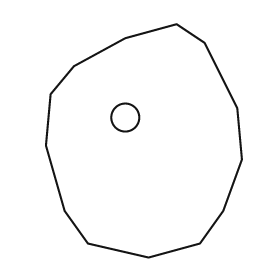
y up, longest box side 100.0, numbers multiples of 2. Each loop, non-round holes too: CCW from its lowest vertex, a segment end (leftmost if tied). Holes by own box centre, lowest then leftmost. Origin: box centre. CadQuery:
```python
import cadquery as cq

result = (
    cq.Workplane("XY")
    .moveTo(2.0, -50.0)
    .lineTo(24.0, -44.0)
    .lineTo(34.0, -30.0)
    .lineTo(42.0, -8.0)
    .lineTo(40.0, 14.0)
    .lineTo(26.0, 42.0)
    .lineTo(14.0, 50.0)
    .lineTo(-8.0, 44.0)
    .lineTo(-30.0, 32.0)
    .lineTo(-40.0, 20.0)
    .lineTo(-42.0, -2.0)
    .lineTo(-34.0, -30.0)
    .lineTo(-24.0, -44.0)
    .close()
    .moveTo(-8.0, 10.0)
    .circle(6.0)
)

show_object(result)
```